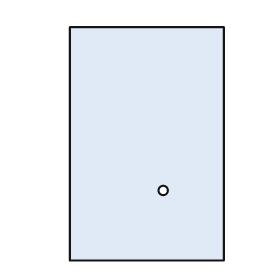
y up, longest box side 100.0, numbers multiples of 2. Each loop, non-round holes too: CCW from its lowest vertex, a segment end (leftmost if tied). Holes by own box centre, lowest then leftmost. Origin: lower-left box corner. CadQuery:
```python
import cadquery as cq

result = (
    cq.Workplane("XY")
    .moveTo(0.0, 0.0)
    .lineTo(66.0, 0.0)
    .lineTo(66.0, 100.0)
    .lineTo(0.0, 100.0)
    .close()
    .moveTo(40.0, 30.0)
    .circle(2.0)
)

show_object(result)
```